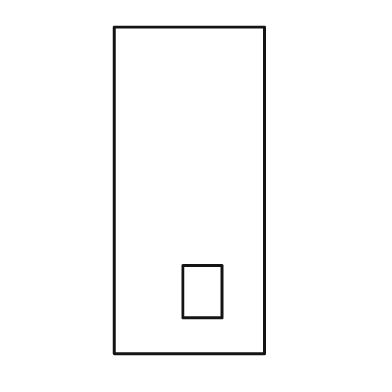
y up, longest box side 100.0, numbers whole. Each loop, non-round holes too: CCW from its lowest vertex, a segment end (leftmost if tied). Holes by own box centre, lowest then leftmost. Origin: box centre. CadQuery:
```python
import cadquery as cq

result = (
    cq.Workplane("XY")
    .moveTo(-23.0, -50.0)
    .lineTo(23.0, -50.0)
    .lineTo(23.0, 50.0)
    .lineTo(-23.0, 50.0)
    .close()
    .moveTo(-2.0, -39.0)
    .lineTo(10.0, -39.0)
    .lineTo(10.0, -23.0)
    .lineTo(-2.0, -23.0)
    .close()
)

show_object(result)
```